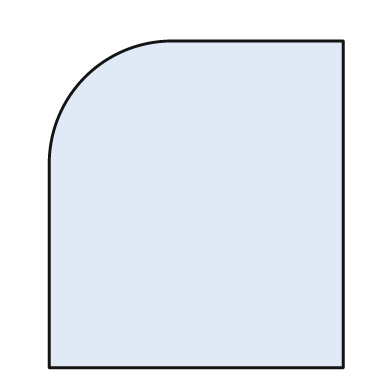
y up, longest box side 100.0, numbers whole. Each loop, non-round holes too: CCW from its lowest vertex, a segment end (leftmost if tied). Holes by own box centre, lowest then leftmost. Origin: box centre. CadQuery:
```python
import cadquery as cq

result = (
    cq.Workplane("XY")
    .moveTo(-45.0, -50.0)
    .lineTo(45.0, -50.0)
    .lineTo(45.0, 50.0)
    .lineTo(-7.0, 50.0)
    .threePointArc((-34.0, 39.0), (-45.0, 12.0))
    .close()
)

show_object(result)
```